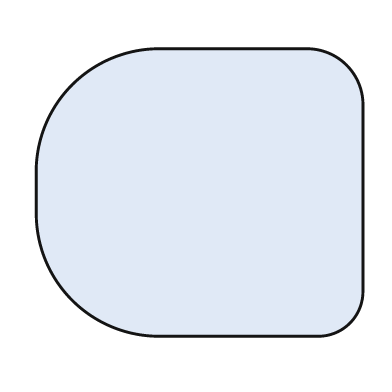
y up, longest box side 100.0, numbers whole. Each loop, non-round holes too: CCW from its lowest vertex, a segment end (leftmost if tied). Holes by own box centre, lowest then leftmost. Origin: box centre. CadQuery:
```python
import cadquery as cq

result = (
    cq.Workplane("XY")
    .moveTo(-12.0, -44.0)
    .lineTo(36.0, -44.0)
    .threePointArc((46.0, -40.0), (50.0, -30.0))
    .lineTo(50.0, 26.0)
    .threePointArc((45.0, 39.0), (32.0, 44.0))
    .lineTo(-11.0, 44.0)
    .threePointArc((-39.0, 33.0), (-50.0, 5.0))
    .lineTo(-50.0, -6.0)
    .threePointArc((-39.0, -33.0), (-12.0, -44.0))
    .close()
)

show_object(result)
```